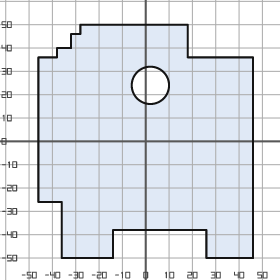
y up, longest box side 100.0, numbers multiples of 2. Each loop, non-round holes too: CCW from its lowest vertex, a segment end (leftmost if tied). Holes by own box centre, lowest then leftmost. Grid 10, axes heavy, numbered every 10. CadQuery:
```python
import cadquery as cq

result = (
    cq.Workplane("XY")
    .moveTo(-36.0, -50.0)
    .lineTo(-14.0, -50.0)
    .lineTo(-14.0, -38.0)
    .lineTo(26.0, -38.0)
    .lineTo(26.0, -50.0)
    .lineTo(46.0, -50.0)
    .lineTo(46.0, 36.0)
    .lineTo(18.0, 36.0)
    .lineTo(18.0, 50.0)
    .lineTo(-28.0, 50.0)
    .lineTo(-28.0, 46.0)
    .lineTo(-32.0, 46.0)
    .lineTo(-32.0, 40.0)
    .lineTo(-38.0, 40.0)
    .lineTo(-38.0, 36.0)
    .lineTo(-46.0, 36.0)
    .lineTo(-46.0, -26.0)
    .lineTo(-36.0, -26.0)
    .close()
    .moveTo(2.0, 24.0)
    .circle(8.0)
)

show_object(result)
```